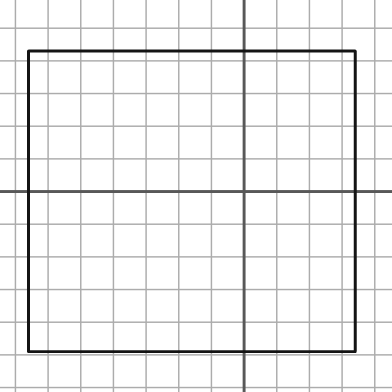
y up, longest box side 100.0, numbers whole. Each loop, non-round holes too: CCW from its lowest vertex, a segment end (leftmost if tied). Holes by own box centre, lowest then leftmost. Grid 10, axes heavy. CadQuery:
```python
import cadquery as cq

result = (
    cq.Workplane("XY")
    .moveTo(-66.0, -49.0)
    .lineTo(34.0, -49.0)
    .lineTo(34.0, 43.0)
    .lineTo(-66.0, 43.0)
    .close()
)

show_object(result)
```